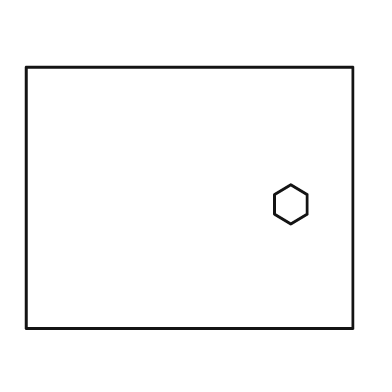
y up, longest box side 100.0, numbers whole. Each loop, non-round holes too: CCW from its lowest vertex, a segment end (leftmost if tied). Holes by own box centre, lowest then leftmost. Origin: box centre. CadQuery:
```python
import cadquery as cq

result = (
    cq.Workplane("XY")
    .moveTo(-50.0, -40.0)
    .lineTo(50.0, -40.0)
    .lineTo(50.0, 40.0)
    .lineTo(-50.0, 40.0)
    .close()
    .moveTo(31.0, -8.0)
    .lineTo(36.0, -5.0)
    .lineTo(36.0, 1.0)
    .lineTo(31.0, 4.0)
    .lineTo(26.0, 1.0)
    .lineTo(26.0, -5.0)
    .close()
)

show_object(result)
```